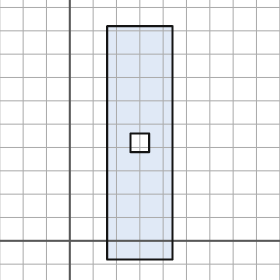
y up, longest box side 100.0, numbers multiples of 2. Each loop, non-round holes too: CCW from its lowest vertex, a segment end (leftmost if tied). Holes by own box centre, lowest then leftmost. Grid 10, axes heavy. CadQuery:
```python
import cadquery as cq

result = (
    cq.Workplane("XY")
    .moveTo(16.0, -8.0)
    .lineTo(44.0, -8.0)
    .lineTo(44.0, 92.0)
    .lineTo(16.0, 92.0)
    .close()
    .moveTo(26.0, 38.0)
    .lineTo(34.0, 38.0)
    .lineTo(34.0, 46.0)
    .lineTo(26.0, 46.0)
    .close()
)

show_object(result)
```